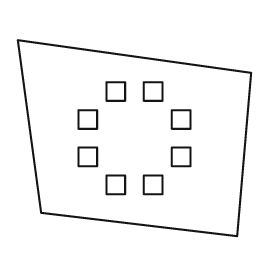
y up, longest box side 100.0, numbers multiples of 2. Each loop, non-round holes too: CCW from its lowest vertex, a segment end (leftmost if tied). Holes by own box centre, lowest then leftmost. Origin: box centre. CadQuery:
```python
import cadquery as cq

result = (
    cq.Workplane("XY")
    .moveTo(44.0, -42.0)
    .lineTo(50.0, 28.0)
    .lineTo(-50.0, 42.0)
    .lineTo(-40.0, -32.0)
    .close()
    .moveTo(-12.0, -24.0)
    .lineTo(-4.0, -24.0)
    .lineTo(-4.0, -16.0)
    .lineTo(-12.0, -16.0)
    .close()
    .moveTo(4.0, -24.0)
    .lineTo(12.0, -24.0)
    .lineTo(12.0, -16.0)
    .lineTo(4.0, -16.0)
    .close()
    .moveTo(-24.0, -12.0)
    .lineTo(-16.0, -12.0)
    .lineTo(-16.0, -4.0)
    .lineTo(-24.0, -4.0)
    .close()
    .moveTo(16.0, -12.0)
    .lineTo(24.0, -12.0)
    .lineTo(24.0, -4.0)
    .lineTo(16.0, -4.0)
    .close()
    .moveTo(-24.0, 4.0)
    .lineTo(-16.0, 4.0)
    .lineTo(-16.0, 12.0)
    .lineTo(-24.0, 12.0)
    .close()
    .moveTo(16.0, 4.0)
    .lineTo(24.0, 4.0)
    .lineTo(24.0, 12.0)
    .lineTo(16.0, 12.0)
    .close()
    .moveTo(-12.0, 16.0)
    .lineTo(-4.0, 16.0)
    .lineTo(-4.0, 24.0)
    .lineTo(-12.0, 24.0)
    .close()
    .moveTo(4.0, 16.0)
    .lineTo(12.0, 16.0)
    .lineTo(12.0, 24.0)
    .lineTo(4.0, 24.0)
    .close()
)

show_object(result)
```